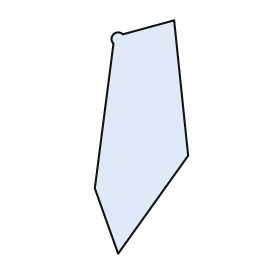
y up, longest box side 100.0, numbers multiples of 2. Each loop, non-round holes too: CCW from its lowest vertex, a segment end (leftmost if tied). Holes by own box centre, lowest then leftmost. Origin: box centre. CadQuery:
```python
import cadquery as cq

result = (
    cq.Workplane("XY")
    .moveTo(-10.0, -50.0)
    .lineTo(20.0, -8.0)
    .lineTo(14.0, 50.0)
    .lineTo(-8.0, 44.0)
    .threePointArc((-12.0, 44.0), (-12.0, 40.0))
    .lineTo(-20.0, -22.0)
    .close()
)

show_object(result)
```